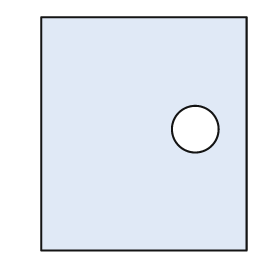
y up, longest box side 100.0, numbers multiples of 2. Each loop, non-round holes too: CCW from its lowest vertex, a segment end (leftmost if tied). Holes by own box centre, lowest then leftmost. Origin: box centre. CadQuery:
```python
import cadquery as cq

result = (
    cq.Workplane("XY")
    .moveTo(-44.0, -50.0)
    .lineTo(44.0, -50.0)
    .lineTo(44.0, 50.0)
    .lineTo(-44.0, 50.0)
    .close()
    .moveTo(22.0, 2.0)
    .circle(10.0)
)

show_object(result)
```